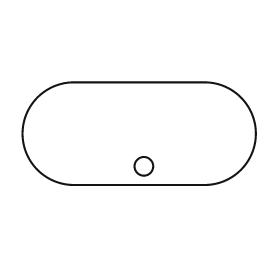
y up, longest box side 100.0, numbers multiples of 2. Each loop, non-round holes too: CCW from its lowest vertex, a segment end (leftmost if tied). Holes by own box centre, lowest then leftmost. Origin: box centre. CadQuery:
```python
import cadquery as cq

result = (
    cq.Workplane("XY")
    .moveTo(-28.0, -22.0)
    .lineTo(28.0, -22.0)
    .threePointArc((50.0, 0.0), (28.0, 22.0))
    .lineTo(-28.0, 22.0)
    .threePointArc((-50.0, 0.0), (-28.0, -22.0))
    .close()
    .moveTo(2.0, -14.0)
    .circle(4.0)
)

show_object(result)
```